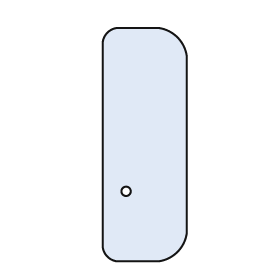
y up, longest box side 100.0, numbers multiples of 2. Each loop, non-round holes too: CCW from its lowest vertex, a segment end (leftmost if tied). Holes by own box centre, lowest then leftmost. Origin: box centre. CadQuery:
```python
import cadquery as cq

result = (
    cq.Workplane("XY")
    .moveTo(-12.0, -50.0)
    .lineTo(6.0, -50.0)
    .threePointArc((14.0, -46.0), (18.0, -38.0))
    .lineTo(18.0, 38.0)
    .threePointArc((14.0, 46.0), (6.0, 50.0))
    .lineTo(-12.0, 50.0)
    .threePointArc((-16.0, 48.0), (-18.0, 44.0))
    .lineTo(-18.0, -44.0)
    .threePointArc((-16.0, -48.0), (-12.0, -50.0))
    .close()
    .moveTo(-8.0, -20.0)
    .circle(2.0)
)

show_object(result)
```